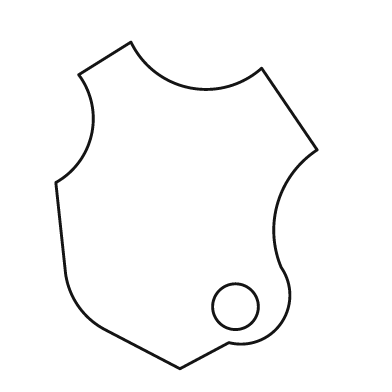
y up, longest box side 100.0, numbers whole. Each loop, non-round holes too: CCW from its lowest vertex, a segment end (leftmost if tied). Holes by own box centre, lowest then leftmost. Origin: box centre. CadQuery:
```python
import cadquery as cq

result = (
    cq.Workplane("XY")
    .moveTo(-2.0, -50.0)
    .lineTo(13.0, -42.0)
    .threePointArc((29.0, -36.0), (29.0, -19.0))
    .threePointArc((28.0, 1.0), (40.0, 17.0))
    .lineTo(23.0, 42.0)
    .threePointArc((1.0, 36.0), (-17.0, 50.0))
    .lineTo(-33.0, 40.0)
    .threePointArc((-29.0, 22.0), (-40.0, 7.0))
    .lineTo(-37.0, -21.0)
    .threePointArc((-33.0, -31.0), (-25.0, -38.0))
    .close()
    .moveTo(15.0, -31.0)
    .circle(7.0)
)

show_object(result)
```